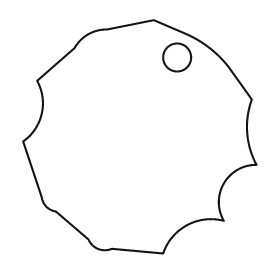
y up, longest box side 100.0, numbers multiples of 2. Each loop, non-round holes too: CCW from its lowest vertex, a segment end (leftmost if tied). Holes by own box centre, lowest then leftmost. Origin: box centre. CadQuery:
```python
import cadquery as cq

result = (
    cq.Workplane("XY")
    .moveTo(10.0, -50.0)
    .threePointArc((20.0, -38.0), (36.0, -36.0))
    .threePointArc((36.0, -20.0), (50.0, -12.0))
    .threePointArc((46.0, 2.0), (48.0, 16.0))
    .lineTo(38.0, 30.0)
    .threePointArc((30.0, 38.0), (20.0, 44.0))
    .lineTo(6.0, 50.0)
    .lineTo(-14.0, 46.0)
    .threePointArc((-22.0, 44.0), (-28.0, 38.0))
    .lineTo(-44.0, 24.0)
    .threePointArc((-42.0, 10.0), (-50.0, -2.0))
    .lineTo(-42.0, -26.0)
    .threePointArc((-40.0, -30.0), (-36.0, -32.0))
    .lineTo(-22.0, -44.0)
    .threePointArc((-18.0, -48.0), (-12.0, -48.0))
    .close()
    .moveTo(16.0, 34.0)
    .circle(6.0)
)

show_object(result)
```